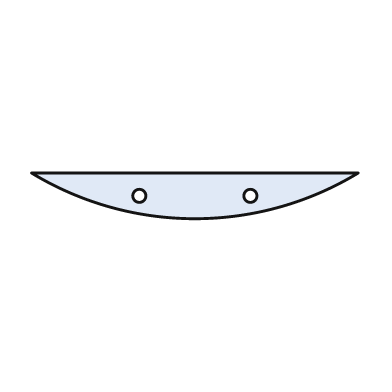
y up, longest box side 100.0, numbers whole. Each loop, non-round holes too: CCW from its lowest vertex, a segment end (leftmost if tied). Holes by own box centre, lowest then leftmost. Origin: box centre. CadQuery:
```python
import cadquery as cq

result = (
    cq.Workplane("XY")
    .moveTo(-50.0, 7.0)
    .threePointArc((0.0, -7.0), (50.0, 7.0))
    .close()
    .moveTo(-17.0, 0.0)
    .circle(2.0)
    .moveTo(17.0, 0.0)
    .circle(2.0)
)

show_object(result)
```